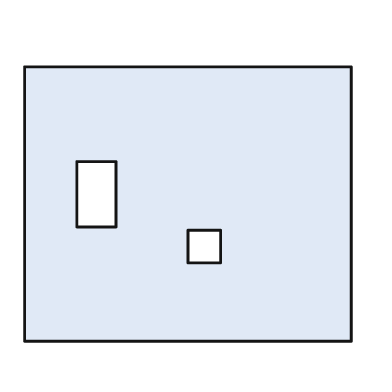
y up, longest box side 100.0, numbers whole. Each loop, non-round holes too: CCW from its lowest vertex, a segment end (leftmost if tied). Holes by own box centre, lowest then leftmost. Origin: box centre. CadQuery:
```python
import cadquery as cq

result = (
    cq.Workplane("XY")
    .moveTo(-50.0, -42.0)
    .lineTo(50.0, -42.0)
    .lineTo(50.0, 42.0)
    .lineTo(-50.0, 42.0)
    .close()
    .moveTo(0.0, -18.0)
    .lineTo(10.0, -18.0)
    .lineTo(10.0, -8.0)
    .lineTo(0.0, -8.0)
    .close()
    .moveTo(-34.0, -7.0)
    .lineTo(-22.0, -7.0)
    .lineTo(-22.0, 13.0)
    .lineTo(-34.0, 13.0)
    .close()
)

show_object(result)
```